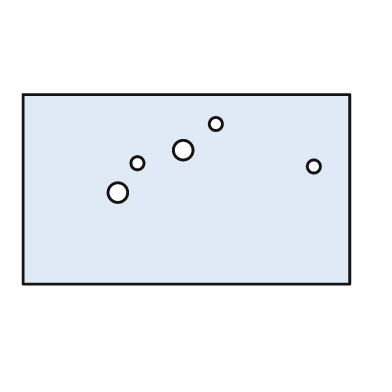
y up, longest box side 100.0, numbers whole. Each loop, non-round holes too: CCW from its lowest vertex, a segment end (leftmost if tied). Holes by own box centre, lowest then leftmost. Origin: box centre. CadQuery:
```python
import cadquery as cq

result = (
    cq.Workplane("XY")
    .moveTo(-50.0, -29.0)
    .lineTo(50.0, -29.0)
    .lineTo(50.0, 29.0)
    .lineTo(-50.0, 29.0)
    .close()
    .moveTo(-21.0, -1.0)
    .circle(3.0)
    .moveTo(39.0, 7.0)
    .circle(2.0)
    .moveTo(-15.0, 8.0)
    .circle(2.0)
    .moveTo(-1.0, 12.0)
    .circle(3.0)
    .moveTo(9.0, 20.0)
    .circle(2.0)
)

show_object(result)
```